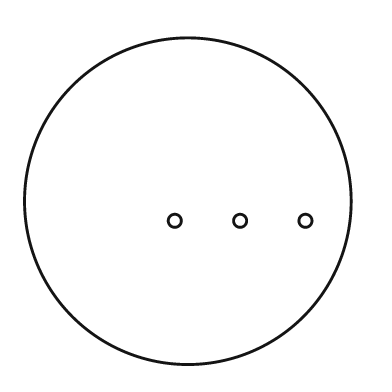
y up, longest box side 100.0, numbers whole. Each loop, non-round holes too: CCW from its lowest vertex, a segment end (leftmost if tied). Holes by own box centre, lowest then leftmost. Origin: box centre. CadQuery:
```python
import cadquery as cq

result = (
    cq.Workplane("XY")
    .moveTo(0.0, 0.0)
    .circle(50.0)
    .moveTo(-4.0, -6.0)
    .circle(2.0)
    .moveTo(16.0, -6.0)
    .circle(2.0)
    .moveTo(36.0, -6.0)
    .circle(2.0)
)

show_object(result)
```